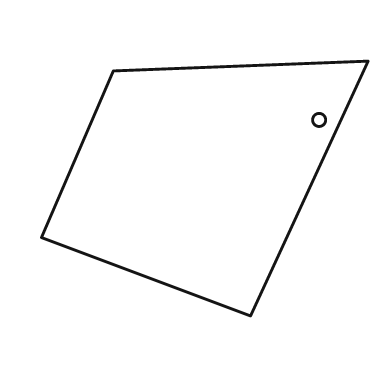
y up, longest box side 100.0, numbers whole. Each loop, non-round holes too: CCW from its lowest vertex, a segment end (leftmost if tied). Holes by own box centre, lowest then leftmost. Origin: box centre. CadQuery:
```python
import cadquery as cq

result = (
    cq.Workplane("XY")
    .moveTo(14.0, -39.0)
    .lineTo(50.0, 39.0)
    .lineTo(-28.0, 36.0)
    .lineTo(-50.0, -15.0)
    .close()
    .moveTo(35.0, 21.0)
    .circle(2.0)
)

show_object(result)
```